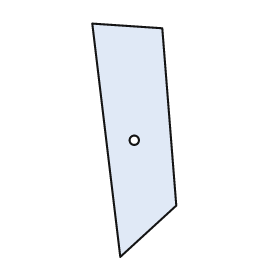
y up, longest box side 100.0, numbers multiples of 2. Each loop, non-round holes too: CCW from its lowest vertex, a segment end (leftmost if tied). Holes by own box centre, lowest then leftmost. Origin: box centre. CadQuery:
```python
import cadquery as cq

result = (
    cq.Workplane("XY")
    .moveTo(-6.0, -50.0)
    .lineTo(18.0, -28.0)
    .lineTo(12.0, 48.0)
    .lineTo(-18.0, 50.0)
    .close()
    .moveTo(0.0, 0.0)
    .circle(2.0)
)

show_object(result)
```